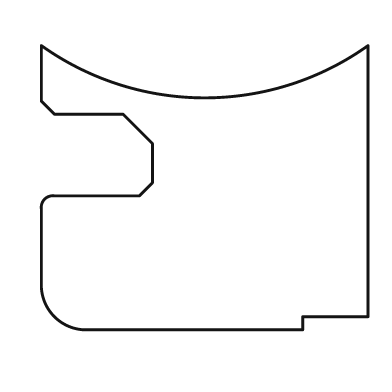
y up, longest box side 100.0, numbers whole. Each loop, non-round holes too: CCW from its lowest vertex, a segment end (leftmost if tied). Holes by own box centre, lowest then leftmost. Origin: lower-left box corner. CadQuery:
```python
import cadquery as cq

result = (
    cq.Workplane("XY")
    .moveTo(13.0, 0.0)
    .lineTo(80.0, 0.0)
    .lineTo(80.0, 4.0)
    .lineTo(100.0, 4.0)
    .lineTo(100.0, 87.0)
    .threePointArc((50.0, 71.0), (0.0, 87.0))
    .lineTo(0.0, 70.0)
    .lineTo(4.0, 66.0)
    .lineTo(25.0, 66.0)
    .lineTo(34.0, 57.0)
    .lineTo(34.0, 45.0)
    .lineTo(30.0, 41.0)
    .lineTo(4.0, 41.0)
    .threePointArc((1.0, 40.0), (0.0, 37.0))
    .lineTo(0.0, 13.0)
    .threePointArc((4.0, 4.0), (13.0, 0.0))
    .close()
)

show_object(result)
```